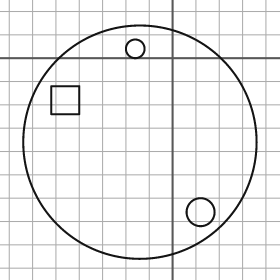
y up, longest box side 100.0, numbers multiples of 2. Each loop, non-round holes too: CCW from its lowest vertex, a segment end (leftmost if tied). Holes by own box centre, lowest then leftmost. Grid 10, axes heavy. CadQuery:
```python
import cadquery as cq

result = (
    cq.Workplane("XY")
    .moveTo(-14.0, -36.0)
    .circle(50.0)
    .moveTo(12.0, -66.0)
    .circle(6.0)
    .moveTo(-52.0, -24.0)
    .lineTo(-40.0, -24.0)
    .lineTo(-40.0, -12.0)
    .lineTo(-52.0, -12.0)
    .close()
    .moveTo(-16.0, 4.0)
    .circle(4.0)
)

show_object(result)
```